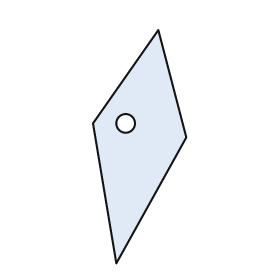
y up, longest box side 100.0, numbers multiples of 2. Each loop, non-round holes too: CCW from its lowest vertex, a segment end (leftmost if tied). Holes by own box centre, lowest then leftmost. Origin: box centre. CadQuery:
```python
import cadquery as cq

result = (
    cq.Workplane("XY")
    .moveTo(-10.0, -50.0)
    .lineTo(20.0, 4.0)
    .lineTo(8.0, 50.0)
    .lineTo(-20.0, 10.0)
    .close()
    .moveTo(-6.0, 10.0)
    .circle(4.0)
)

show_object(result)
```